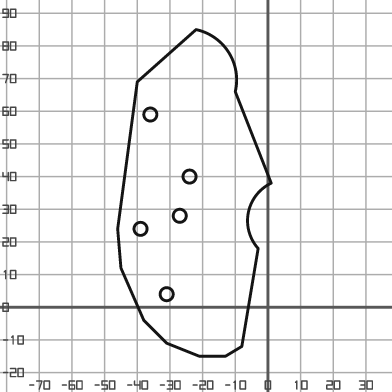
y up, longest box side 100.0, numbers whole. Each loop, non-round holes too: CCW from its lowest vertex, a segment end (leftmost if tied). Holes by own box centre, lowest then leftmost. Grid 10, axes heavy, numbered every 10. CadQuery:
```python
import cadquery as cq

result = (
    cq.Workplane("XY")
    .moveTo(-21.0, -15.0)
    .lineTo(-13.0, -15.0)
    .lineTo(-8.0, -12.0)
    .lineTo(-3.0, 18.0)
    .threePointArc((-6.0, 29.0), (1.0, 38.0))
    .lineTo(-10.0, 66.0)
    .threePointArc((-12.0, 78.0), (-22.0, 85.0))
    .lineTo(-40.0, 69.0)
    .lineTo(-46.0, 24.0)
    .lineTo(-45.0, 12.0)
    .lineTo(-38.0, -4.0)
    .lineTo(-31.0, -11.0)
    .close()
    .moveTo(-31.0, 4.0)
    .circle(2.0)
    .moveTo(-39.0, 24.0)
    .circle(2.0)
    .moveTo(-27.0, 28.0)
    .circle(2.0)
    .moveTo(-24.0, 40.0)
    .circle(2.0)
    .moveTo(-36.0, 59.0)
    .circle(2.0)
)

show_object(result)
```